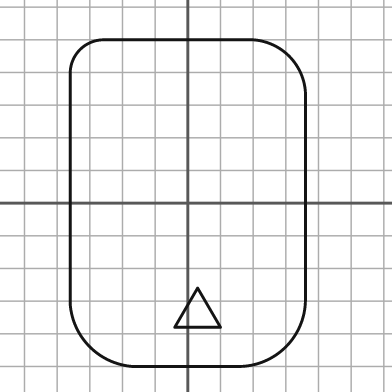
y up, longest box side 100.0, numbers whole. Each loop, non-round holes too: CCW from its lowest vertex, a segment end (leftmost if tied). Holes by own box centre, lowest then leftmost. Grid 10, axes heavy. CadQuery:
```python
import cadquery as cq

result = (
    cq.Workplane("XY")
    .moveTo(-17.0, -50.0)
    .lineTo(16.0, -50.0)
    .threePointArc((30.0, -44.0), (36.0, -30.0))
    .lineTo(36.0, 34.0)
    .threePointArc((31.0, 45.0), (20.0, 50.0))
    .lineTo(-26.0, 50.0)
    .threePointArc((-33.0, 47.0), (-36.0, 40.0))
    .lineTo(-36.0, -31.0)
    .threePointArc((-30.0, -44.0), (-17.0, -50.0))
    .close()
    .moveTo(-4.0, -38.0)
    .lineTo(10.0, -38.0)
    .lineTo(3.0, -26.0)
    .close()
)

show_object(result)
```